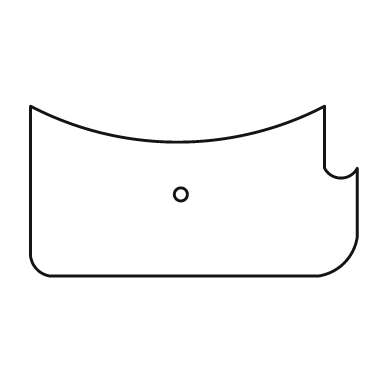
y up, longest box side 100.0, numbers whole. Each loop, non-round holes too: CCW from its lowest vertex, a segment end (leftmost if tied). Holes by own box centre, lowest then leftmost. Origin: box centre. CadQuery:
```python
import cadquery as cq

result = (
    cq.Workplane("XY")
    .moveTo(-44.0, -26.0)
    .lineTo(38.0, -26.0)
    .threePointArc((46.0, -22.0), (50.0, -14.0))
    .lineTo(50.0, 7.0)
    .threePointArc((45.0, 4.0), (40.0, 7.0))
    .lineTo(40.0, 26.0)
    .threePointArc((-5.0, 15.0), (-50.0, 26.0))
    .lineTo(-50.0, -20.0)
    .threePointArc((-48.0, -24.0), (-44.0, -26.0))
    .close()
    .moveTo(-4.0, -1.0)
    .circle(2.0)
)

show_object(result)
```